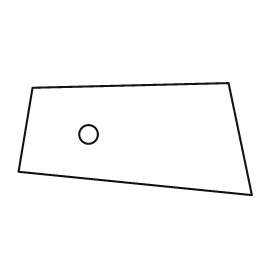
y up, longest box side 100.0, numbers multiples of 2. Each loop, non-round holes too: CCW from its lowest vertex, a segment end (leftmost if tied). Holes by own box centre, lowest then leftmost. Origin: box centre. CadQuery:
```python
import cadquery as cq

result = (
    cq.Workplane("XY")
    .moveTo(50.0, -24.0)
    .lineTo(40.0, 24.0)
    .lineTo(-44.0, 22.0)
    .lineTo(-50.0, -14.0)
    .close()
    .moveTo(-20.0, 2.0)
    .circle(4.0)
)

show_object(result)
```